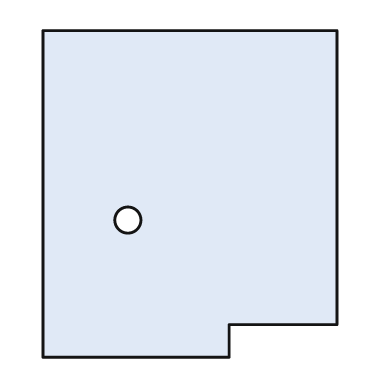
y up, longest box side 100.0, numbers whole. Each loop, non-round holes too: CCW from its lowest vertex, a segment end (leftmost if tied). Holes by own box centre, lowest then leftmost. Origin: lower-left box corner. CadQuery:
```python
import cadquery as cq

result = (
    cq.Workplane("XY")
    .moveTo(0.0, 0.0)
    .lineTo(57.0, 0.0)
    .lineTo(57.0, 10.0)
    .lineTo(90.0, 10.0)
    .lineTo(90.0, 100.0)
    .lineTo(0.0, 100.0)
    .close()
    .moveTo(26.0, 42.0)
    .circle(4.0)
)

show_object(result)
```